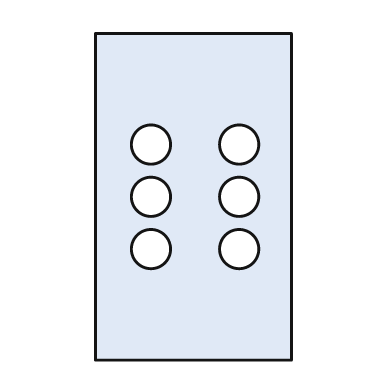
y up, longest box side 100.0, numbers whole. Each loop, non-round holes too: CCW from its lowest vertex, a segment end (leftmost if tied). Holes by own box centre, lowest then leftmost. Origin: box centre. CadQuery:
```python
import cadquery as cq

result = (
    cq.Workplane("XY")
    .moveTo(-30.0, -50.0)
    .lineTo(30.0, -50.0)
    .lineTo(30.0, 50.0)
    .lineTo(-30.0, 50.0)
    .close()
    .moveTo(-13.0, -16.0)
    .circle(6.0)
    .moveTo(14.0, -16.0)
    .circle(6.0)
    .moveTo(-13.0, 0.0)
    .circle(6.0)
    .moveTo(14.0, 0.0)
    .circle(6.0)
    .moveTo(-13.0, 16.0)
    .circle(6.0)
    .moveTo(14.0, 16.0)
    .circle(6.0)
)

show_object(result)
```